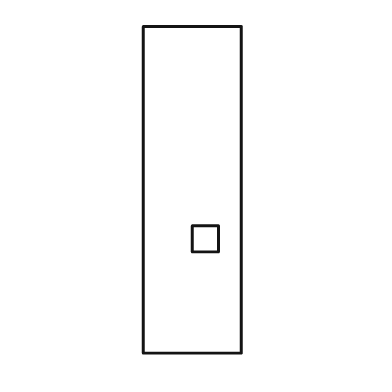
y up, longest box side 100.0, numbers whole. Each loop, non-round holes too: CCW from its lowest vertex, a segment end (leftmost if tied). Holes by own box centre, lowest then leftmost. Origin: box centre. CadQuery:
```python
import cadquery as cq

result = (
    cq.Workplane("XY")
    .moveTo(-15.0, -50.0)
    .lineTo(15.0, -50.0)
    .lineTo(15.0, 50.0)
    .lineTo(-15.0, 50.0)
    .close()
    .moveTo(0.0, -19.0)
    .lineTo(8.0, -19.0)
    .lineTo(8.0, -11.0)
    .lineTo(0.0, -11.0)
    .close()
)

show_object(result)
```